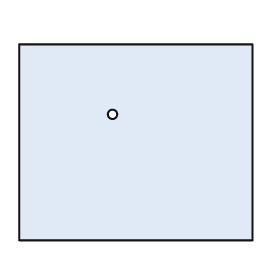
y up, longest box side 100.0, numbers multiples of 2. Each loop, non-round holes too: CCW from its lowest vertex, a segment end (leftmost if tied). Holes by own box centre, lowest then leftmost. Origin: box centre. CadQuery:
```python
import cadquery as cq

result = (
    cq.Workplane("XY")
    .moveTo(-50.0, -42.0)
    .lineTo(50.0, -42.0)
    .lineTo(50.0, 42.0)
    .lineTo(-50.0, 42.0)
    .close()
    .moveTo(-10.0, 12.0)
    .circle(2.0)
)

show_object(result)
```